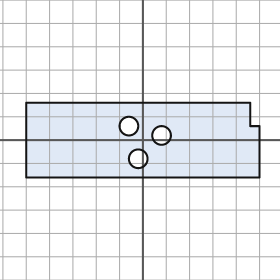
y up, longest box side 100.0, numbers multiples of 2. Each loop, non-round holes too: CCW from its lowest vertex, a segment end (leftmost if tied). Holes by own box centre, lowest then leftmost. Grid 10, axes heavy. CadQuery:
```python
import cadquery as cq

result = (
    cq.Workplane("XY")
    .moveTo(-50.0, -16.0)
    .lineTo(50.0, -16.0)
    .lineTo(50.0, 6.0)
    .lineTo(46.0, 6.0)
    .lineTo(46.0, 16.0)
    .lineTo(-50.0, 16.0)
    .close()
    .moveTo(-2.0, -8.0)
    .circle(4.0)
    .moveTo(8.0, 2.0)
    .circle(4.0)
    .moveTo(-6.0, 6.0)
    .circle(4.0)
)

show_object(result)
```